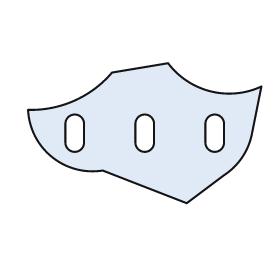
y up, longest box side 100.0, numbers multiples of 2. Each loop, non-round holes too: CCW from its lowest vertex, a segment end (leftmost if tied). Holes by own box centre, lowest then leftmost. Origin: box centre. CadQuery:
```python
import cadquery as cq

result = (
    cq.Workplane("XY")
    .moveTo(18.0, -30.0)
    .lineTo(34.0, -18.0)
    .threePointArc((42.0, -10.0), (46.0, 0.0))
    .lineTo(50.0, 20.0)
    .threePointArc((28.0, 18.0), (10.0, 30.0))
    .lineTo(-14.0, 26.0)
    .threePointArc((-30.0, 14.0), (-50.0, 10.0))
    .threePointArc((-40.0, -10.0), (-18.0, -16.0))
    .close()
    .moveTo(-34.0, -4.0)
    .threePointArc((-30.0, -8.0), (-26.0, -4.0))
    .lineTo(-26.0, 4.0)
    .threePointArc((-30.0, 8.0), (-34.0, 4.0))
    .close()
    .moveTo(-4.0, -4.0)
    .threePointArc((0.0, -8.0), (4.0, -4.0))
    .lineTo(4.0, 4.0)
    .threePointArc((0.0, 8.0), (-4.0, 4.0))
    .close()
    .moveTo(26.0, -4.0)
    .threePointArc((30.0, -8.0), (34.0, -4.0))
    .lineTo(34.0, 4.0)
    .threePointArc((30.0, 8.0), (26.0, 4.0))
    .close()
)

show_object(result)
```